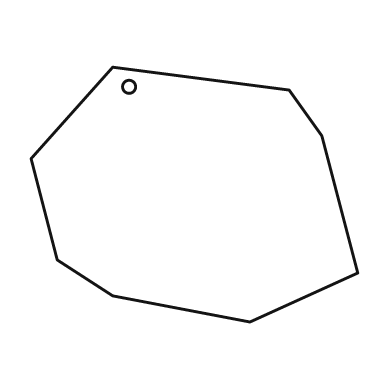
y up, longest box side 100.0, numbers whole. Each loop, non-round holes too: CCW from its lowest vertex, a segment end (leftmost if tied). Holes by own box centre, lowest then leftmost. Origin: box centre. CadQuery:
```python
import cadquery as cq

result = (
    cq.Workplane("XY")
    .moveTo(17.0, -39.0)
    .lineTo(50.0, -24.0)
    .lineTo(39.0, 18.0)
    .lineTo(29.0, 32.0)
    .lineTo(-25.0, 39.0)
    .lineTo(-50.0, 11.0)
    .lineTo(-42.0, -20.0)
    .lineTo(-25.0, -31.0)
    .close()
    .moveTo(-20.0, 33.0)
    .circle(2.0)
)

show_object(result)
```